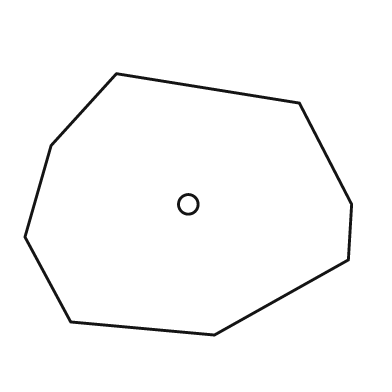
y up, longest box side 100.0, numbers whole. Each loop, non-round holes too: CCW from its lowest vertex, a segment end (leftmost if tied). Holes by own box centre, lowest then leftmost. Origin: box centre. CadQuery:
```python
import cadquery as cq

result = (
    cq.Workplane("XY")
    .moveTo(8.0, -40.0)
    .lineTo(49.0, -17.0)
    .lineTo(50.0, 0.0)
    .lineTo(34.0, 31.0)
    .lineTo(-22.0, 40.0)
    .lineTo(-42.0, 18.0)
    .lineTo(-50.0, -10.0)
    .lineTo(-36.0, -36.0)
    .close()
    .moveTo(0.0, 0.0)
    .circle(3.0)
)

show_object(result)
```